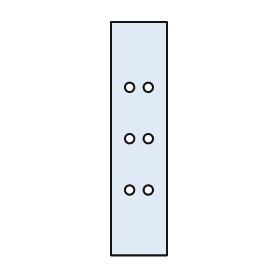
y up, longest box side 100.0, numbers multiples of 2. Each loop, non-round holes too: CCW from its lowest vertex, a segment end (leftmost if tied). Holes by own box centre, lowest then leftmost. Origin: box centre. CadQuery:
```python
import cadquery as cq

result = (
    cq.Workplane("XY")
    .moveTo(-12.0, -50.0)
    .lineTo(12.0, -50.0)
    .lineTo(12.0, 50.0)
    .lineTo(-12.0, 50.0)
    .close()
    .moveTo(-4.0, -22.0)
    .circle(2.0)
    .moveTo(4.0, -22.0)
    .circle(2.0)
    .moveTo(-4.0, 0.0)
    .circle(2.0)
    .moveTo(4.0, 0.0)
    .circle(2.0)
    .moveTo(-4.0, 22.0)
    .circle(2.0)
    .moveTo(4.0, 22.0)
    .circle(2.0)
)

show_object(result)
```